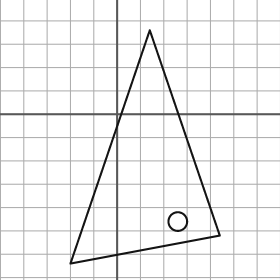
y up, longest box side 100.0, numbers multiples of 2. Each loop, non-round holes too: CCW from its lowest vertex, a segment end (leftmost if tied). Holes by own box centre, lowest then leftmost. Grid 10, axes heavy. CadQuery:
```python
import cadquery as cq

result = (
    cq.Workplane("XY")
    .moveTo(-20.0, -64.0)
    .lineTo(44.0, -52.0)
    .lineTo(14.0, 36.0)
    .close()
    .moveTo(26.0, -46.0)
    .circle(4.0)
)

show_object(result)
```